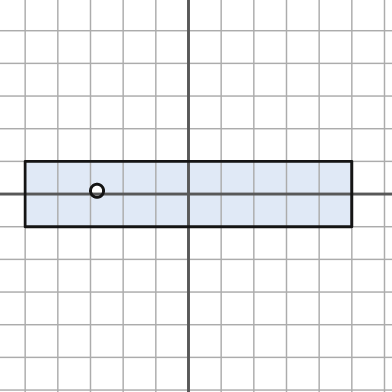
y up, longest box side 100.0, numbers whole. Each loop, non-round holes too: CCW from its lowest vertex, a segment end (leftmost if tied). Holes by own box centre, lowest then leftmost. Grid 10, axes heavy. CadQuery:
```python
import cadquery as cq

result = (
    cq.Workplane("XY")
    .moveTo(-50.0, -10.0)
    .lineTo(50.0, -10.0)
    .lineTo(50.0, 10.0)
    .lineTo(-50.0, 10.0)
    .close()
    .moveTo(-28.0, 1.0)
    .circle(2.0)
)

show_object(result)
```